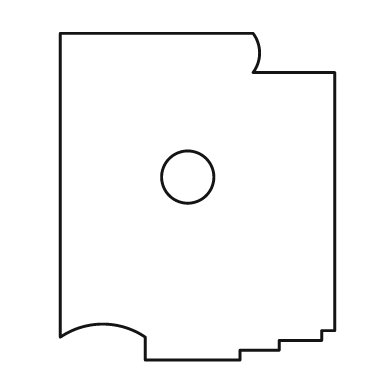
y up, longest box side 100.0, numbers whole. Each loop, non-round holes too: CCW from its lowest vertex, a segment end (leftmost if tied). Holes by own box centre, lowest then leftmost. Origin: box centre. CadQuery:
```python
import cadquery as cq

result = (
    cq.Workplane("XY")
    .moveTo(-16.0, -50.0)
    .lineTo(13.0, -50.0)
    .lineTo(13.0, -47.0)
    .lineTo(25.0, -47.0)
    .lineTo(25.0, -44.0)
    .lineTo(38.0, -44.0)
    .lineTo(38.0, -41.0)
    .lineTo(42.0, -41.0)
    .lineTo(42.0, 38.0)
    .lineTo(17.0, 38.0)
    .threePointArc((19.0, 44.0), (17.0, 50.0))
    .lineTo(-42.0, 50.0)
    .lineTo(-42.0, -43.0)
    .threePointArc((-29.0, -39.0), (-16.0, -43.0))
    .close()
    .moveTo(-3.0, 6.0)
    .circle(8.0)
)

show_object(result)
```